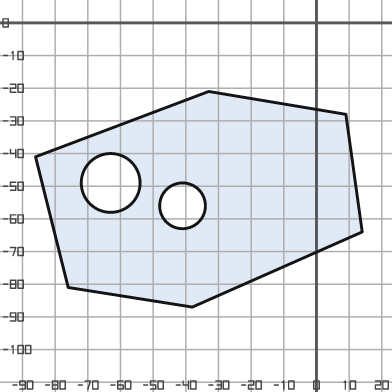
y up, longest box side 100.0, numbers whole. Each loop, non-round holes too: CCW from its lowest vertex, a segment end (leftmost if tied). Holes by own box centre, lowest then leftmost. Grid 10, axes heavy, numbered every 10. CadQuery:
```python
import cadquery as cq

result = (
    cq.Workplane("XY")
    .moveTo(-38.0, -87.0)
    .lineTo(14.0, -64.0)
    .lineTo(9.0, -28.0)
    .lineTo(-33.0, -21.0)
    .lineTo(-86.0, -41.0)
    .lineTo(-76.0, -81.0)
    .close()
    .moveTo(-41.0, -56.0)
    .circle(7.0)
    .moveTo(-63.0, -49.0)
    .circle(9.0)
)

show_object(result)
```